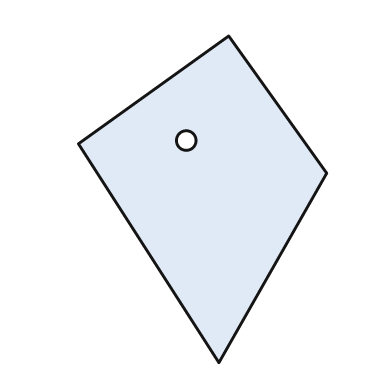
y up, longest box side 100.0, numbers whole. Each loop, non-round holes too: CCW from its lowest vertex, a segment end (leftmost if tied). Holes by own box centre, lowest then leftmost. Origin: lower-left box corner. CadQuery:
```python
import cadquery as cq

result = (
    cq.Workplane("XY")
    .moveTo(43.0, 0.0)
    .lineTo(76.0, 58.0)
    .lineTo(46.0, 100.0)
    .lineTo(0.0, 67.0)
    .close()
    .moveTo(33.0, 68.0)
    .circle(3.0)
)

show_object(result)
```